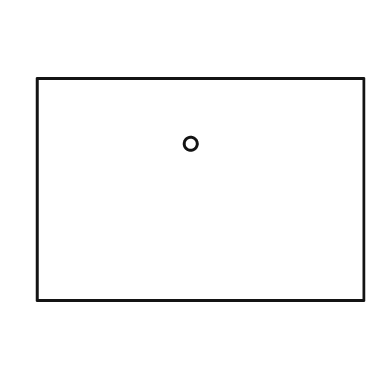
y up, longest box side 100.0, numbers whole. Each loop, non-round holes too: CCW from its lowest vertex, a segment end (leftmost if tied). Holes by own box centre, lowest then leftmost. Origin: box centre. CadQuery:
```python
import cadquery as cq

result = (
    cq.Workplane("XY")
    .moveTo(-50.0, -34.0)
    .lineTo(50.0, -34.0)
    .lineTo(50.0, 34.0)
    .lineTo(-50.0, 34.0)
    .close()
    .moveTo(-3.0, 14.0)
    .circle(2.0)
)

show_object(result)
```